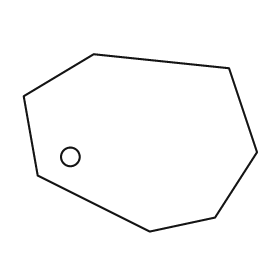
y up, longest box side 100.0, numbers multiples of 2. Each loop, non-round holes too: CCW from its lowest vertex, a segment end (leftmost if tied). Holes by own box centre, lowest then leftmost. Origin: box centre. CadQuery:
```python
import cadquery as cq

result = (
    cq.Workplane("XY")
    .moveTo(4.0, -38.0)
    .lineTo(32.0, -32.0)
    .lineTo(50.0, -4.0)
    .lineTo(38.0, 32.0)
    .lineTo(-20.0, 38.0)
    .lineTo(-50.0, 20.0)
    .lineTo(-44.0, -14.0)
    .close()
    .moveTo(-30.0, -6.0)
    .circle(4.0)
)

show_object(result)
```